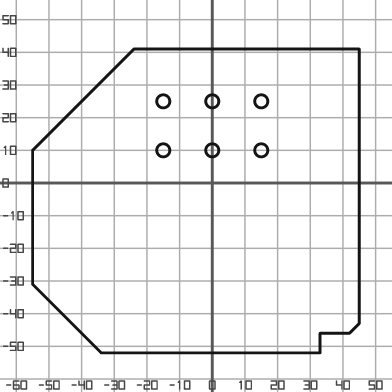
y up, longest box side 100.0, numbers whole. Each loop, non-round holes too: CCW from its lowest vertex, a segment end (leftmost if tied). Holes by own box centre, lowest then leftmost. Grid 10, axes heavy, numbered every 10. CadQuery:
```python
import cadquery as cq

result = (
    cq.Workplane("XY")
    .moveTo(-34.0, -52.0)
    .lineTo(33.0, -52.0)
    .lineTo(33.0, -46.0)
    .lineTo(42.0, -46.0)
    .lineTo(45.0, -43.0)
    .lineTo(45.0, 41.0)
    .lineTo(-24.0, 41.0)
    .lineTo(-55.0, 10.0)
    .lineTo(-55.0, -31.0)
    .close()
    .moveTo(-15.0, 10.0)
    .circle(2.0)
    .moveTo(0.0, 10.0)
    .circle(2.0)
    .moveTo(15.0, 10.0)
    .circle(2.0)
    .moveTo(-15.0, 25.0)
    .circle(2.0)
    .moveTo(0.0, 25.0)
    .circle(2.0)
    .moveTo(15.0, 25.0)
    .circle(2.0)
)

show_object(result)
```